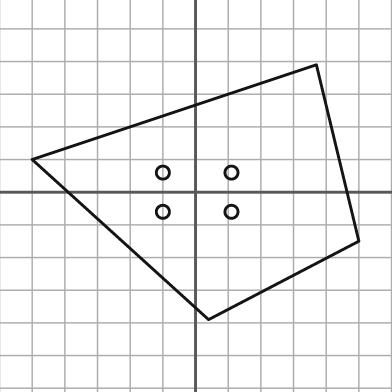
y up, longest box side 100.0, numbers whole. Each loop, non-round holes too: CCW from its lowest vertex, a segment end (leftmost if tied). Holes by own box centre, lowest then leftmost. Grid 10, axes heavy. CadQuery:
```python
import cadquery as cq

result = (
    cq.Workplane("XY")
    .moveTo(4.0, -39.0)
    .lineTo(50.0, -15.0)
    .lineTo(37.0, 39.0)
    .lineTo(-50.0, 10.0)
    .close()
    .moveTo(-10.0, -6.0)
    .circle(2.0)
    .moveTo(11.0, -6.0)
    .circle(2.0)
    .moveTo(-10.0, 6.0)
    .circle(2.0)
    .moveTo(11.0, 6.0)
    .circle(2.0)
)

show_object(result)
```